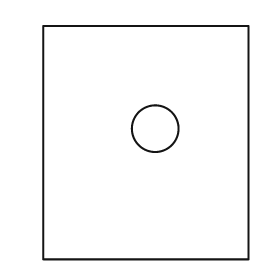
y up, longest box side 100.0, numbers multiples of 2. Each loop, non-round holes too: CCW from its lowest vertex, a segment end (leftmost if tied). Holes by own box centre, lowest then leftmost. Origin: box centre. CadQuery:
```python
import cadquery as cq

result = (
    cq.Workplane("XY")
    .moveTo(-44.0, -50.0)
    .lineTo(44.0, -50.0)
    .lineTo(44.0, 50.0)
    .lineTo(-44.0, 50.0)
    .close()
    .moveTo(4.0, 6.0)
    .circle(10.0)
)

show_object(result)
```